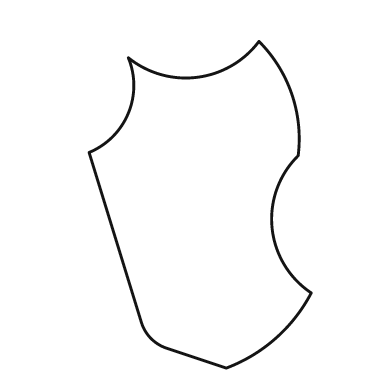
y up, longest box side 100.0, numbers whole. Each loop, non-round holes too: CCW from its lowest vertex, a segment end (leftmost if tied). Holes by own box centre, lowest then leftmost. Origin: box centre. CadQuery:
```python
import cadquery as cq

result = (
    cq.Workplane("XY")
    .moveTo(8.0, -50.0)
    .threePointArc((23.0, -41.0), (34.0, -27.0))
    .threePointArc((22.0, -7.0), (30.0, 15.0))
    .threePointArc((28.0, 34.0), (18.0, 50.0))
    .threePointArc((-1.0, 39.0), (-22.0, 45.0))
    .threePointArc((-22.0, 28.0), (-34.0, 16.0))
    .lineTo(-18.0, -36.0)
    .threePointArc((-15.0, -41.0), (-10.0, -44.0))
    .close()
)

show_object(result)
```